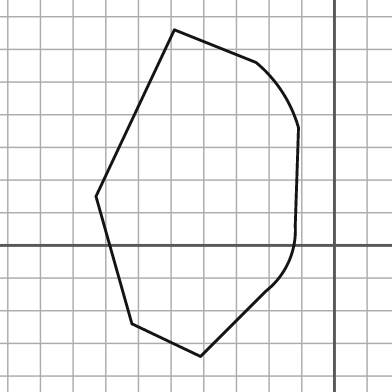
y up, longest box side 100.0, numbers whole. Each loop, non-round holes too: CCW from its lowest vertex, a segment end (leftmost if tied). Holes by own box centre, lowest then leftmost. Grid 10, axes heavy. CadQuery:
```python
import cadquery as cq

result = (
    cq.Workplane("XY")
    .moveTo(-41.0, -34.0)
    .lineTo(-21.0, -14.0)
    .threePointArc((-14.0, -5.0), (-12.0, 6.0))
    .lineTo(-11.0, 36.0)
    .threePointArc((-16.0, 47.0), (-24.0, 56.0))
    .lineTo(-49.0, 66.0)
    .lineTo(-73.0, 15.0)
    .lineTo(-62.0, -24.0)
    .close()
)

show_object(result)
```